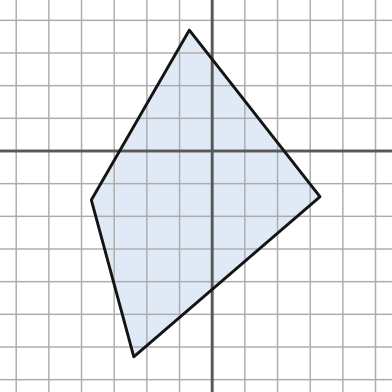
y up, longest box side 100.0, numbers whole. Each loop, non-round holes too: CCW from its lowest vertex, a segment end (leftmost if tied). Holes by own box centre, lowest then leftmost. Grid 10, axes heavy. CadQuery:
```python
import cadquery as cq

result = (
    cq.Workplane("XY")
    .moveTo(-24.0, -63.0)
    .lineTo(33.0, -14.0)
    .lineTo(-7.0, 37.0)
    .lineTo(-37.0, -15.0)
    .close()
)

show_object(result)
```